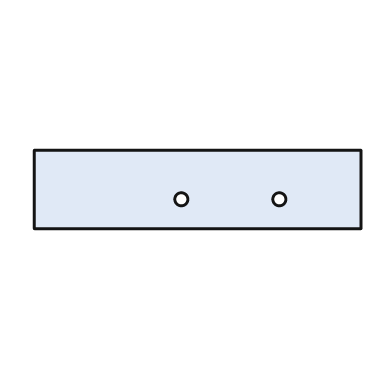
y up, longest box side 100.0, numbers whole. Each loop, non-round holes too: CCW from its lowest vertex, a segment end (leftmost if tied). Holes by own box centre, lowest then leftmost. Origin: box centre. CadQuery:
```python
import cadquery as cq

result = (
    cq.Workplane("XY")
    .moveTo(-50.0, -12.0)
    .lineTo(50.0, -12.0)
    .lineTo(50.0, 12.0)
    .lineTo(-50.0, 12.0)
    .close()
    .moveTo(-5.0, -3.0)
    .circle(2.0)
    .moveTo(25.0, -3.0)
    .circle(2.0)
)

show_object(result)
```